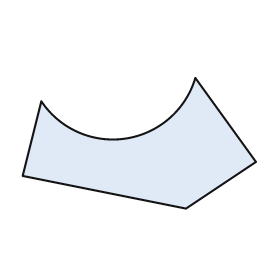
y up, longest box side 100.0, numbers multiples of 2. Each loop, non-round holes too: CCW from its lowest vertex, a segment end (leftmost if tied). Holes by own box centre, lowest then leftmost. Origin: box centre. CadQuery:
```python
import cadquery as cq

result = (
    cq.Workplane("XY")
    .moveTo(20.0, -28.0)
    .lineTo(50.0, -8.0)
    .lineTo(24.0, 28.0)
    .threePointArc((-6.0, 2.0), (-42.0, 18.0))
    .lineTo(-50.0, -14.0)
    .close()
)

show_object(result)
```